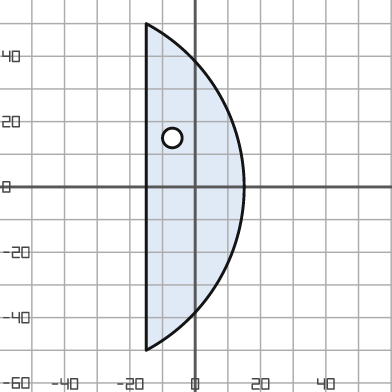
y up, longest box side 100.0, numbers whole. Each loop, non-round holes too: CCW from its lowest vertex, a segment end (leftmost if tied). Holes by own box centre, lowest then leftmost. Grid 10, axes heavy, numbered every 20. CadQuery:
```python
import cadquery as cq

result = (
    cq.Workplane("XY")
    .moveTo(-15.0, -50.0)
    .threePointArc((15.0, 0.0), (-15.0, 50.0))
    .close()
    .moveTo(-7.0, 15.0)
    .circle(3.0)
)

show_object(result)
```